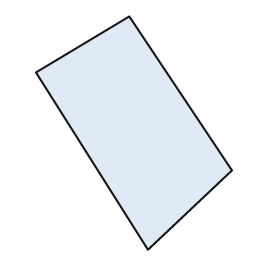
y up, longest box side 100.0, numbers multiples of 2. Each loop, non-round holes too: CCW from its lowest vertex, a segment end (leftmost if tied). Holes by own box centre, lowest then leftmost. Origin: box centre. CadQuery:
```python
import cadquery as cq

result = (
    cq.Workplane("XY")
    .moveTo(6.0, -50.0)
    .lineTo(42.0, -16.0)
    .lineTo(-2.0, 50.0)
    .lineTo(-42.0, 26.0)
    .close()
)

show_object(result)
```